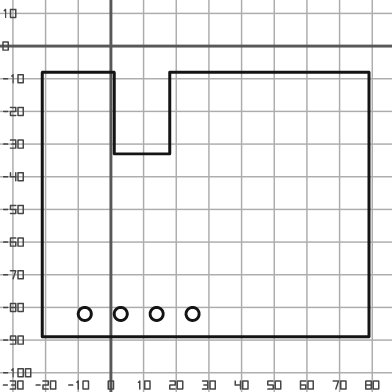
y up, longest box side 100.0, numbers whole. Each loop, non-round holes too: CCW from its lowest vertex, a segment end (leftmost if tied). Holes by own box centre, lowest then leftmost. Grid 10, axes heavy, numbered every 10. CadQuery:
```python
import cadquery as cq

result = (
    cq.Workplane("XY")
    .moveTo(-21.0, -89.0)
    .lineTo(79.0, -89.0)
    .lineTo(79.0, -8.0)
    .lineTo(18.0, -8.0)
    .lineTo(18.0, -33.0)
    .lineTo(1.0, -33.0)
    .lineTo(1.0, -8.0)
    .lineTo(-21.0, -8.0)
    .close()
    .moveTo(-8.0, -82.0)
    .circle(2.0)
    .moveTo(3.0, -82.0)
    .circle(2.0)
    .moveTo(14.0, -82.0)
    .circle(2.0)
    .moveTo(25.0, -82.0)
    .circle(2.0)
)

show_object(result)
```